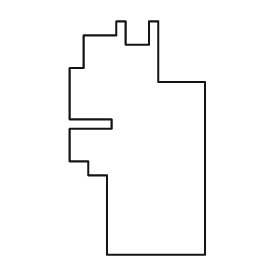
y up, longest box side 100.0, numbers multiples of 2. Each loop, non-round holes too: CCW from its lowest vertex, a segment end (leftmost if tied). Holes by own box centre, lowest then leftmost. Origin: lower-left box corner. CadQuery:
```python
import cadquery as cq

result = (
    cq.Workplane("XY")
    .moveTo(16.0, 0.0)
    .lineTo(58.0, 0.0)
    .lineTo(58.0, 74.0)
    .lineTo(38.0, 74.0)
    .lineTo(38.0, 100.0)
    .lineTo(34.0, 100.0)
    .lineTo(34.0, 90.0)
    .lineTo(24.0, 90.0)
    .lineTo(24.0, 100.0)
    .lineTo(20.0, 100.0)
    .lineTo(20.0, 94.0)
    .lineTo(6.0, 94.0)
    .lineTo(6.0, 80.0)
    .lineTo(0.0, 80.0)
    .lineTo(0.0, 58.0)
    .lineTo(18.0, 58.0)
    .lineTo(18.0, 54.0)
    .lineTo(0.0, 54.0)
    .lineTo(0.0, 40.0)
    .lineTo(8.0, 40.0)
    .lineTo(8.0, 34.0)
    .lineTo(16.0, 34.0)
    .close()
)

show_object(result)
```